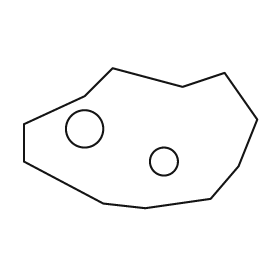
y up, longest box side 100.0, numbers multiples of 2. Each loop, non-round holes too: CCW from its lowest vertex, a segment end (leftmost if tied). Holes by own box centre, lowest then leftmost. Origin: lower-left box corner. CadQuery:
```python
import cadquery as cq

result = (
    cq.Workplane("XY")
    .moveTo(52.0, 0.0)
    .lineTo(80.0, 4.0)
    .lineTo(92.0, 18.0)
    .lineTo(100.0, 38.0)
    .lineTo(86.0, 58.0)
    .lineTo(68.0, 52.0)
    .lineTo(38.0, 60.0)
    .lineTo(26.0, 48.0)
    .lineTo(0.0, 36.0)
    .lineTo(0.0, 20.0)
    .lineTo(34.0, 2.0)
    .close()
    .moveTo(60.0, 20.0)
    .circle(6.0)
    .moveTo(26.0, 34.0)
    .circle(8.0)
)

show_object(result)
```